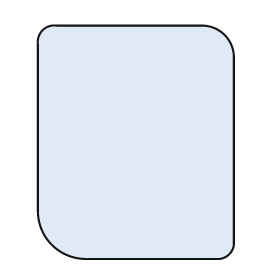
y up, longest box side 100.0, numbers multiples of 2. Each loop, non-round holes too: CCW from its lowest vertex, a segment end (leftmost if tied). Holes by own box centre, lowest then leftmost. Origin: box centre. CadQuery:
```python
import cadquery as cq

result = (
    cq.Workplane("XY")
    .moveTo(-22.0, -50.0)
    .lineTo(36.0, -50.0)
    .threePointArc((40.0, -48.0), (42.0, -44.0))
    .lineTo(42.0, 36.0)
    .threePointArc((38.0, 46.0), (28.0, 50.0))
    .lineTo(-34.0, 50.0)
    .threePointArc((-40.0, 48.0), (-42.0, 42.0))
    .lineTo(-42.0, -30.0)
    .threePointArc((-36.0, -44.0), (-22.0, -50.0))
    .close()
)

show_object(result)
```